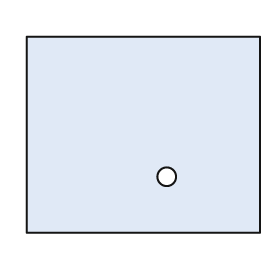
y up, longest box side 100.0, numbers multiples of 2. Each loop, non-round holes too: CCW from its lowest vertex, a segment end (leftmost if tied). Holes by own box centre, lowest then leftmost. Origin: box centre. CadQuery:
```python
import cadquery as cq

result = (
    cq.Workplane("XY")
    .moveTo(-50.0, -42.0)
    .lineTo(50.0, -42.0)
    .lineTo(50.0, 42.0)
    .lineTo(-50.0, 42.0)
    .close()
    .moveTo(10.0, -18.0)
    .circle(4.0)
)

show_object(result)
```